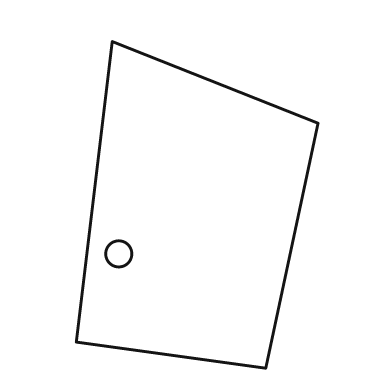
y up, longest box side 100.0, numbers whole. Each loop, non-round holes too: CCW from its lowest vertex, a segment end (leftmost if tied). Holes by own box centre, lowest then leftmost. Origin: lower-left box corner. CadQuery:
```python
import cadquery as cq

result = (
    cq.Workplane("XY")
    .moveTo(58.0, 0.0)
    .lineTo(74.0, 75.0)
    .lineTo(11.0, 100.0)
    .lineTo(0.0, 8.0)
    .close()
    .moveTo(13.0, 35.0)
    .circle(4.0)
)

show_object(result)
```